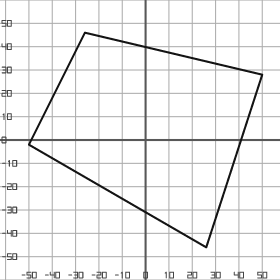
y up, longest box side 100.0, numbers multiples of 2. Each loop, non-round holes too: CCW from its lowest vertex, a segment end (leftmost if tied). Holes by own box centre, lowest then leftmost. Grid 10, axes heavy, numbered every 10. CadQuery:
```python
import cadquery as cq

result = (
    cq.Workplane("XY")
    .moveTo(26.0, -46.0)
    .lineTo(50.0, 28.0)
    .lineTo(-26.0, 46.0)
    .lineTo(-50.0, -2.0)
    .close()
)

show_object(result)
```